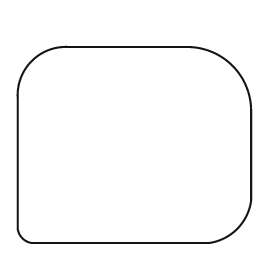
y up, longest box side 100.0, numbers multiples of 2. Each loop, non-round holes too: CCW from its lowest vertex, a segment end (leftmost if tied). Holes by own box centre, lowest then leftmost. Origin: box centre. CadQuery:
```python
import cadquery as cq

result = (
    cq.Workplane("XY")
    .moveTo(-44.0, -42.0)
    .lineTo(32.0, -42.0)
    .threePointArc((44.0, -36.0), (50.0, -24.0))
    .lineTo(50.0, 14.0)
    .threePointArc((42.0, 34.0), (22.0, 42.0))
    .lineTo(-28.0, 42.0)
    .threePointArc((-44.0, 36.0), (-50.0, 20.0))
    .lineTo(-50.0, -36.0)
    .threePointArc((-48.0, -40.0), (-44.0, -42.0))
    .close()
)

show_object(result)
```